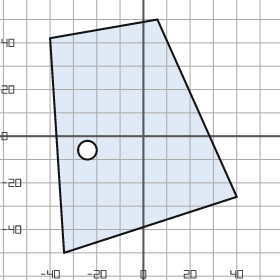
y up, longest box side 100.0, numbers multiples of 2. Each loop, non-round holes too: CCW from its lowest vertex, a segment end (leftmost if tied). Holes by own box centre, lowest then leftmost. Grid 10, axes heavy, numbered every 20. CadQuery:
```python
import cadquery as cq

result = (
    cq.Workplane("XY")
    .moveTo(-34.0, -50.0)
    .lineTo(40.0, -26.0)
    .lineTo(6.0, 50.0)
    .lineTo(-40.0, 42.0)
    .close()
    .moveTo(-24.0, -6.0)
    .circle(4.0)
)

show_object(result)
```